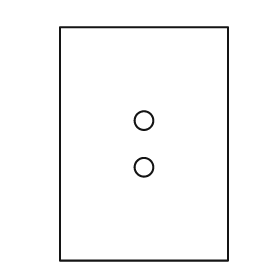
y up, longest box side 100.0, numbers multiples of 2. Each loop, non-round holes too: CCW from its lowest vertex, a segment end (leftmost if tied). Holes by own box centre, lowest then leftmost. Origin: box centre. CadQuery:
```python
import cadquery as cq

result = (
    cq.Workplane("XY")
    .moveTo(-36.0, -50.0)
    .lineTo(36.0, -50.0)
    .lineTo(36.0, 50.0)
    .lineTo(-36.0, 50.0)
    .close()
    .moveTo(0.0, -10.0)
    .circle(4.0)
    .moveTo(0.0, 10.0)
    .circle(4.0)
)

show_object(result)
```